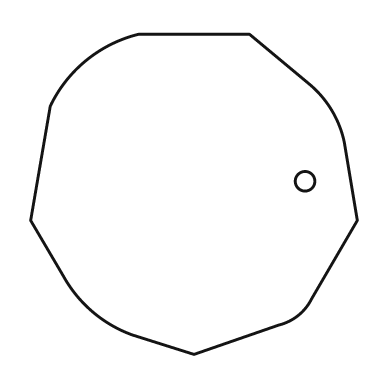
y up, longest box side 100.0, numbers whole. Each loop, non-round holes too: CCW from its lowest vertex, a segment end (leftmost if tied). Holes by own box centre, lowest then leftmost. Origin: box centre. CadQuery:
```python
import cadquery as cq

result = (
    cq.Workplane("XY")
    .moveTo(0.0, -49.0)
    .lineTo(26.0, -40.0)
    .threePointArc((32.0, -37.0), (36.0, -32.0))
    .lineTo(50.0, -8.0)
    .lineTo(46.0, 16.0)
    .threePointArc((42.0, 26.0), (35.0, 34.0))
    .lineTo(17.0, 49.0)
    .lineTo(-17.0, 49.0)
    .threePointArc((-33.0, 41.0), (-44.0, 27.0))
    .lineTo(-50.0, -8.0)
    .lineTo(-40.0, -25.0)
    .threePointArc((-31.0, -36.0), (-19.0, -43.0))
    .close()
    .moveTo(34.0, 4.0)
    .circle(3.0)
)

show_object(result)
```